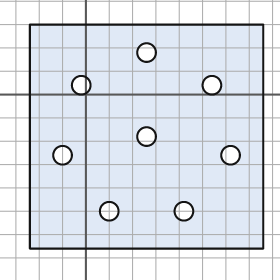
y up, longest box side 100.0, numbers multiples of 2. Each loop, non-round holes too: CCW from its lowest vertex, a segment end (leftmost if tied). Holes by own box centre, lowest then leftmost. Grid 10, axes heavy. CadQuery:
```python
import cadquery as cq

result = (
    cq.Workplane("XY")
    .moveTo(-24.0, -66.0)
    .lineTo(76.0, -66.0)
    .lineTo(76.0, 30.0)
    .lineTo(-24.0, 30.0)
    .close()
    .moveTo(10.0, -50.0)
    .circle(4.0)
    .moveTo(42.0, -50.0)
    .circle(4.0)
    .moveTo(-10.0, -26.0)
    .circle(4.0)
    .moveTo(62.0, -26.0)
    .circle(4.0)
    .moveTo(26.0, -18.0)
    .circle(4.0)
    .moveTo(-2.0, 4.0)
    .circle(4.0)
    .moveTo(54.0, 4.0)
    .circle(4.0)
    .moveTo(26.0, 18.0)
    .circle(4.0)
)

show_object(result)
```